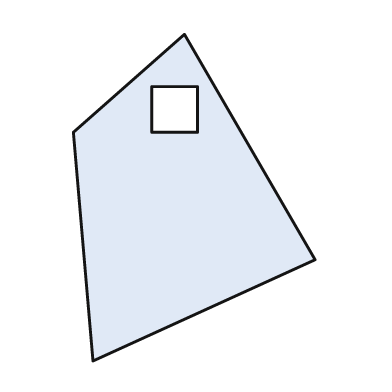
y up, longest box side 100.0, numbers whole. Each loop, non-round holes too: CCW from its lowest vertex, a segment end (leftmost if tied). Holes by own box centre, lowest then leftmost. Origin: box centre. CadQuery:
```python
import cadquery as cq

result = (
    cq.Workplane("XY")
    .moveTo(-31.0, -50.0)
    .lineTo(37.0, -19.0)
    .lineTo(-3.0, 50.0)
    .lineTo(-37.0, 20.0)
    .close()
    .moveTo(-13.0, 20.0)
    .lineTo(1.0, 20.0)
    .lineTo(1.0, 34.0)
    .lineTo(-13.0, 34.0)
    .close()
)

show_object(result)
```